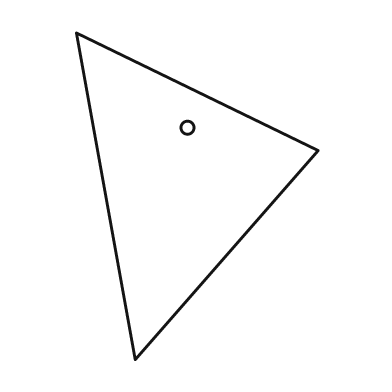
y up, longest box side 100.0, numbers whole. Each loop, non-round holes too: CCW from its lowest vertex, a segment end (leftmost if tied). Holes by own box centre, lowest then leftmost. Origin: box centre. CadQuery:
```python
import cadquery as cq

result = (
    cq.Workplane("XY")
    .moveTo(-19.0, -50.0)
    .lineTo(37.0, 14.0)
    .lineTo(-37.0, 50.0)
    .close()
    .moveTo(-3.0, 21.0)
    .circle(2.0)
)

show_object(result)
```